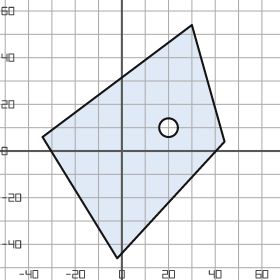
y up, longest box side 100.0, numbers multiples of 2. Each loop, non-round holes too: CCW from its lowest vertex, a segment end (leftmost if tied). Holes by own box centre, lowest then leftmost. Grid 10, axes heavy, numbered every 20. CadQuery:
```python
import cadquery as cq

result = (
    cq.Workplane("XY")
    .moveTo(-2.0, -46.0)
    .lineTo(44.0, 4.0)
    .lineTo(30.0, 54.0)
    .lineTo(-34.0, 6.0)
    .close()
    .moveTo(20.0, 10.0)
    .circle(4.0)
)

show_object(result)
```